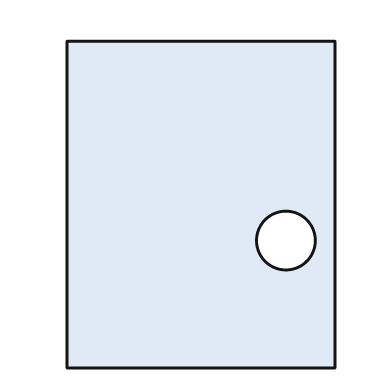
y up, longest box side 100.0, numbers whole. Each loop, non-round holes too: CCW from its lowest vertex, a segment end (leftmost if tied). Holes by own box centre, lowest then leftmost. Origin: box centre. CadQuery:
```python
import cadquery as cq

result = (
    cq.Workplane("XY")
    .moveTo(-41.0, -50.0)
    .lineTo(41.0, -50.0)
    .lineTo(41.0, 50.0)
    .lineTo(-41.0, 50.0)
    .close()
    .moveTo(26.0, -11.0)
    .circle(9.0)
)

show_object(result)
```